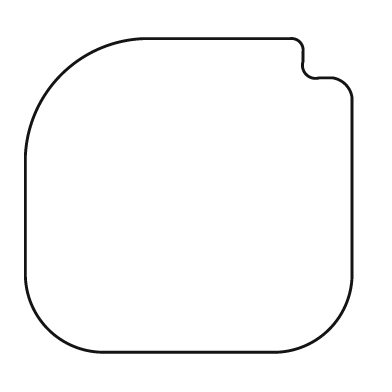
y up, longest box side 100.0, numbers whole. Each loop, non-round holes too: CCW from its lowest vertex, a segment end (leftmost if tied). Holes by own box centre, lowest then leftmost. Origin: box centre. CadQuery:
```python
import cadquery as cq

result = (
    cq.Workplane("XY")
    .moveTo(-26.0, -48.0)
    .lineTo(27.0, -48.0)
    .threePointArc((43.0, -41.0), (50.0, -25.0))
    .lineTo(50.0, 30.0)
    .threePointArc((48.0, 34.0), (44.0, 36.0))
    .lineTo(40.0, 36.0)
    .threePointArc((36.0, 37.0), (35.0, 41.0))
    .lineTo(35.0, 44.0)
    .threePointArc((34.0, 47.0), (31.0, 48.0))
    .lineTo(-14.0, 48.0)
    .threePointArc((-39.0, 37.0), (-50.0, 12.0))
    .lineTo(-50.0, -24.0)
    .threePointArc((-43.0, -41.0), (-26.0, -48.0))
    .close()
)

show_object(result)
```